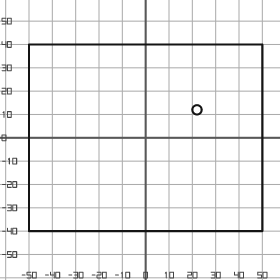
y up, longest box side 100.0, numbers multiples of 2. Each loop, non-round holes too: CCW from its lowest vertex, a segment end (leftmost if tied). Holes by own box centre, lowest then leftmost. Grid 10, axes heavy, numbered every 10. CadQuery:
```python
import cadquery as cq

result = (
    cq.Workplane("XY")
    .moveTo(-50.0, -40.0)
    .lineTo(50.0, -40.0)
    .lineTo(50.0, 40.0)
    .lineTo(-50.0, 40.0)
    .close()
    .moveTo(22.0, 12.0)
    .circle(2.0)
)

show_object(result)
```